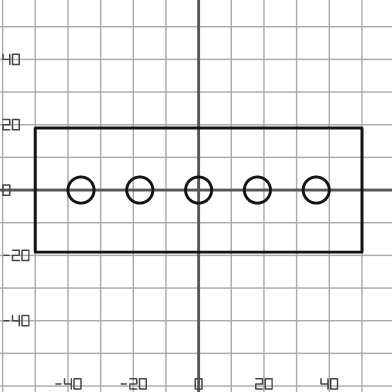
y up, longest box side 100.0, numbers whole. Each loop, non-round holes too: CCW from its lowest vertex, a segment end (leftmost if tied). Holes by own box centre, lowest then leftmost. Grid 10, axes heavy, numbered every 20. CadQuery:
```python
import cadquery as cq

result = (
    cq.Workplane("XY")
    .moveTo(-50.0, -19.0)
    .lineTo(50.0, -19.0)
    .lineTo(50.0, 19.0)
    .lineTo(-50.0, 19.0)
    .close()
    .moveTo(-36.0, 0.0)
    .circle(4.0)
    .moveTo(-18.0, 0.0)
    .circle(4.0)
    .moveTo(0.0, 0.0)
    .circle(4.0)
    .moveTo(18.0, 0.0)
    .circle(4.0)
    .moveTo(36.0, 0.0)
    .circle(4.0)
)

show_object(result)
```